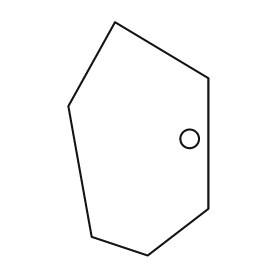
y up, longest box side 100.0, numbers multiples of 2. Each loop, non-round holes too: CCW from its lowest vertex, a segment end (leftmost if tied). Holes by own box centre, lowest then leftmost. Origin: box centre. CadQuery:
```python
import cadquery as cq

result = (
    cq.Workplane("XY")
    .moveTo(4.0, -50.0)
    .lineTo(30.0, -30.0)
    .lineTo(30.0, 26.0)
    .lineTo(-10.0, 50.0)
    .lineTo(-30.0, 14.0)
    .lineTo(-20.0, -42.0)
    .close()
    .moveTo(22.0, 0.0)
    .circle(4.0)
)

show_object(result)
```